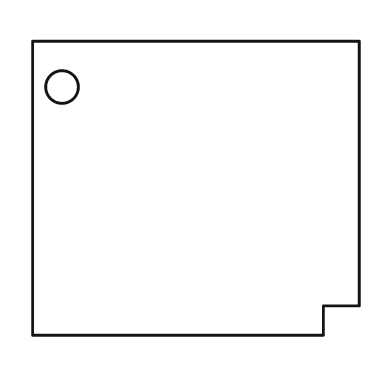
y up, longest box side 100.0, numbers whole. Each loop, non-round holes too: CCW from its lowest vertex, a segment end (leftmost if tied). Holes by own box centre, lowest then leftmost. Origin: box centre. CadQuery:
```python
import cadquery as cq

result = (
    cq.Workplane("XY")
    .moveTo(-50.0, -45.0)
    .lineTo(39.0, -45.0)
    .lineTo(39.0, -36.0)
    .lineTo(50.0, -36.0)
    .lineTo(50.0, 45.0)
    .lineTo(-50.0, 45.0)
    .close()
    .moveTo(-41.0, 31.0)
    .circle(5.0)
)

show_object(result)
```